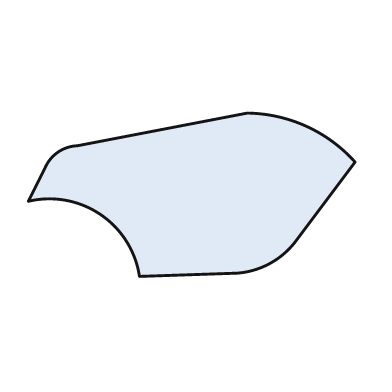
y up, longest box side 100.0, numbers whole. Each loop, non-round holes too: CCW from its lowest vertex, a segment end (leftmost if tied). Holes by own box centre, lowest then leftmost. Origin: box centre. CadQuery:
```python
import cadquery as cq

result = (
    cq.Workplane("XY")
    .moveTo(-16.0, -25.0)
    .lineTo(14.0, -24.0)
    .threePointArc((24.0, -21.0), (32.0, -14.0))
    .lineTo(50.0, 10.0)
    .threePointArc((35.0, 21.0), (17.0, 25.0))
    .lineTo(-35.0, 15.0)
    .threePointArc((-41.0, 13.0), (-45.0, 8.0))
    .lineTo(-50.0, -2.0)
    .threePointArc((-28.0, -6.0), (-16.0, -25.0))
    .close()
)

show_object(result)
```